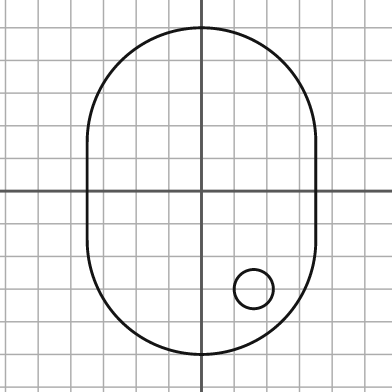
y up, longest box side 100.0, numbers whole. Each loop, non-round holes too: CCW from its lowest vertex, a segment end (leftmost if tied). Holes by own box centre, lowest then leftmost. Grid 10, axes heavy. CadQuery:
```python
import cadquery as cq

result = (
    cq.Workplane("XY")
    .moveTo(-35.0, -15.0)
    .threePointArc((0.0, -50.0), (35.0, -15.0))
    .lineTo(35.0, 15.0)
    .threePointArc((0.0, 50.0), (-35.0, 15.0))
    .close()
    .moveTo(16.0, -30.0)
    .circle(6.0)
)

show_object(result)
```